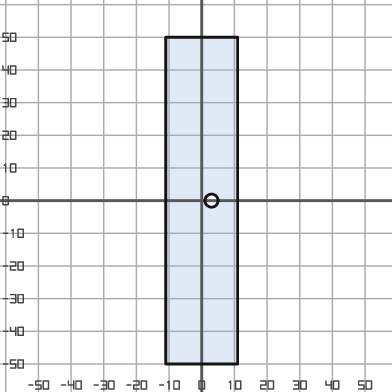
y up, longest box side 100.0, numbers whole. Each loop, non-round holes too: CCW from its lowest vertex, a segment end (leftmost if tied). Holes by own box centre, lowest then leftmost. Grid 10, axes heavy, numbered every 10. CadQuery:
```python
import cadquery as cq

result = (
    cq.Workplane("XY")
    .moveTo(-11.0, -50.0)
    .lineTo(11.0, -50.0)
    .lineTo(11.0, 50.0)
    .lineTo(-11.0, 50.0)
    .close()
    .moveTo(3.0, 0.0)
    .circle(2.0)
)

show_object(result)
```